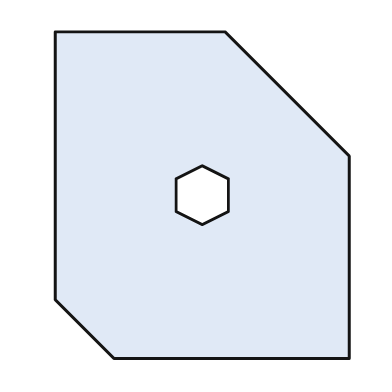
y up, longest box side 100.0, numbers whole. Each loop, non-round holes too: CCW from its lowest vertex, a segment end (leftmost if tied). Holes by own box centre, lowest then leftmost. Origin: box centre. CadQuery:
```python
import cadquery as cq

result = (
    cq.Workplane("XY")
    .moveTo(-27.0, -50.0)
    .lineTo(45.0, -50.0)
    .lineTo(45.0, 12.0)
    .lineTo(7.0, 50.0)
    .lineTo(-45.0, 50.0)
    .lineTo(-45.0, -32.0)
    .close()
    .moveTo(0.0, -9.0)
    .lineTo(8.0, -5.0)
    .lineTo(8.0, 5.0)
    .lineTo(0.0, 9.0)
    .lineTo(-8.0, 5.0)
    .lineTo(-8.0, -5.0)
    .close()
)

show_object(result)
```